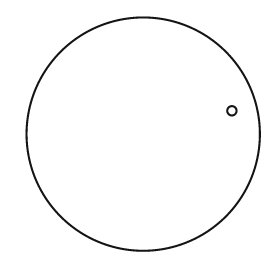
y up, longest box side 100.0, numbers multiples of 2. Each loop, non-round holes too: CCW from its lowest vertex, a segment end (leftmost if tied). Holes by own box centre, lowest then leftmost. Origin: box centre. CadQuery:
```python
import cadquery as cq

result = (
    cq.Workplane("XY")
    .moveTo(0.0, 0.0)
    .circle(50.0)
    .moveTo(38.0, 10.0)
    .circle(2.0)
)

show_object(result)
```